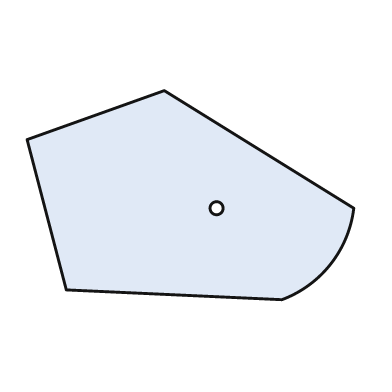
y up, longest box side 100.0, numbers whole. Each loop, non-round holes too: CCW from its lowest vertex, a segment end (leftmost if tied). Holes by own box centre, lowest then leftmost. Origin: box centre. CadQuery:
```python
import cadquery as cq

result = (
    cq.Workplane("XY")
    .moveTo(28.0, -32.0)
    .threePointArc((43.0, -21.0), (50.0, -4.0))
    .lineTo(-8.0, 32.0)
    .lineTo(-50.0, 17.0)
    .lineTo(-38.0, -29.0)
    .close()
    .moveTo(8.0, -4.0)
    .circle(2.0)
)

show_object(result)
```